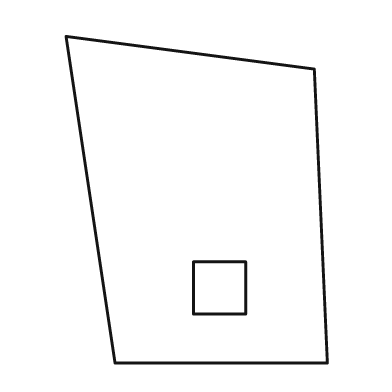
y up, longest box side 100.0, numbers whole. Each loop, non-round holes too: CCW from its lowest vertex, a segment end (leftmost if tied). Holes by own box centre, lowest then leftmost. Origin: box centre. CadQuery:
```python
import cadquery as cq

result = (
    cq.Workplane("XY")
    .moveTo(-25.0, -50.0)
    .lineTo(40.0, -50.0)
    .lineTo(36.0, 40.0)
    .lineTo(-40.0, 50.0)
    .close()
    .moveTo(-1.0, -35.0)
    .lineTo(15.0, -35.0)
    .lineTo(15.0, -19.0)
    .lineTo(-1.0, -19.0)
    .close()
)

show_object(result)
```